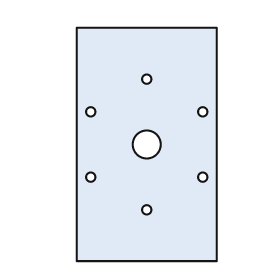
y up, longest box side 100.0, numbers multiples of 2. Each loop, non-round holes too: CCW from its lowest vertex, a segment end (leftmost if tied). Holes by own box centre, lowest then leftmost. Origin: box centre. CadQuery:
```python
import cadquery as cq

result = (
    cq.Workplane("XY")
    .moveTo(-30.0, -50.0)
    .lineTo(30.0, -50.0)
    .lineTo(30.0, 50.0)
    .lineTo(-30.0, 50.0)
    .close()
    .moveTo(0.0, -28.0)
    .circle(2.0)
    .moveTo(-24.0, -14.0)
    .circle(2.0)
    .moveTo(24.0, -14.0)
    .circle(2.0)
    .moveTo(0.0, 0.0)
    .circle(6.0)
    .moveTo(-24.0, 14.0)
    .circle(2.0)
    .moveTo(24.0, 14.0)
    .circle(2.0)
    .moveTo(0.0, 28.0)
    .circle(2.0)
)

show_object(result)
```